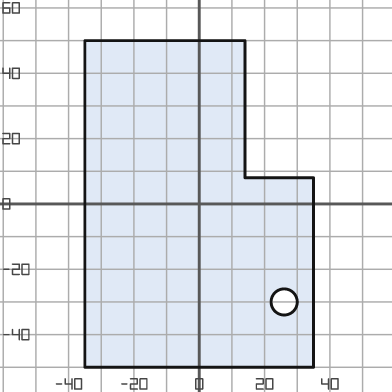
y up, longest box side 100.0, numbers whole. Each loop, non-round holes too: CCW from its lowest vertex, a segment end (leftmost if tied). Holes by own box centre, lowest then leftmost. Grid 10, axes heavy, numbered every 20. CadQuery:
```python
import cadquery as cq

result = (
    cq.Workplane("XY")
    .moveTo(-35.0, -50.0)
    .lineTo(35.0, -50.0)
    .lineTo(35.0, 8.0)
    .lineTo(14.0, 8.0)
    .lineTo(14.0, 50.0)
    .lineTo(-35.0, 50.0)
    .close()
    .moveTo(26.0, -30.0)
    .circle(4.0)
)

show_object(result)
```